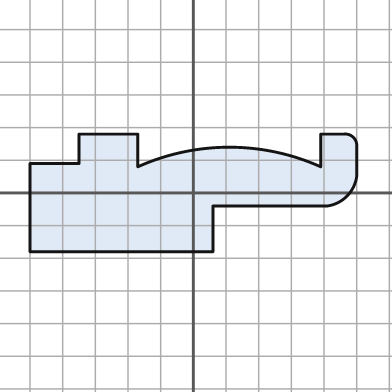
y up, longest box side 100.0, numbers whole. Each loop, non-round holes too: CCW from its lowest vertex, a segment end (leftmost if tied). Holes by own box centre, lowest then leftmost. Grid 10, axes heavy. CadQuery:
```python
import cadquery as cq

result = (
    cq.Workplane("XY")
    .moveTo(-50.0, -18.0)
    .lineTo(6.0, -18.0)
    .lineTo(6.0, -4.0)
    .lineTo(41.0, -4.0)
    .threePointArc((47.0, -1.0), (50.0, 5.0))
    .lineTo(50.0, 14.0)
    .threePointArc((49.0, 17.0), (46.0, 18.0))
    .lineTo(39.0, 18.0)
    .lineTo(39.0, 8.0)
    .threePointArc((11.0, 14.0), (-17.0, 8.0))
    .lineTo(-17.0, 18.0)
    .lineTo(-35.0, 18.0)
    .lineTo(-35.0, 9.0)
    .lineTo(-50.0, 9.0)
    .close()
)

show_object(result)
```